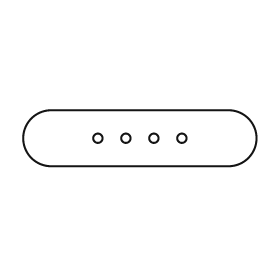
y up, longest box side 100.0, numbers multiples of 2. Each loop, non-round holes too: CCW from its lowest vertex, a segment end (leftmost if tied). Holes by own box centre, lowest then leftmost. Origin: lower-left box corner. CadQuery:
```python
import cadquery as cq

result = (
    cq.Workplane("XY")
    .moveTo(12.0, 0.0)
    .lineTo(88.0, 0.0)
    .threePointArc((100.0, 12.0), (88.0, 24.0))
    .lineTo(12.0, 24.0)
    .threePointArc((0.0, 12.0), (12.0, 0.0))
    .close()
    .moveTo(32.0, 12.0)
    .circle(2.0)
    .moveTo(44.0, 12.0)
    .circle(2.0)
    .moveTo(56.0, 12.0)
    .circle(2.0)
    .moveTo(68.0, 12.0)
    .circle(2.0)
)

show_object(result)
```